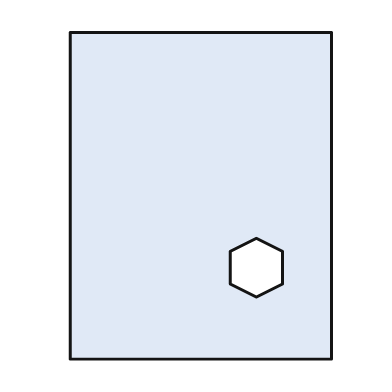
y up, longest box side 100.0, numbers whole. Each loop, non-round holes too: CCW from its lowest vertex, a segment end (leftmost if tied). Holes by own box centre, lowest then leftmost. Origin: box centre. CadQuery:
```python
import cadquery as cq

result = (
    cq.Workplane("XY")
    .moveTo(-40.0, -50.0)
    .lineTo(40.0, -50.0)
    .lineTo(40.0, 50.0)
    .lineTo(-40.0, 50.0)
    .close()
    .moveTo(17.0, -31.0)
    .lineTo(25.0, -27.0)
    .lineTo(25.0, -17.0)
    .lineTo(17.0, -13.0)
    .lineTo(9.0, -17.0)
    .lineTo(9.0, -27.0)
    .close()
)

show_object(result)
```